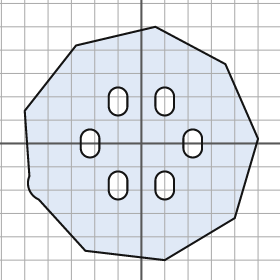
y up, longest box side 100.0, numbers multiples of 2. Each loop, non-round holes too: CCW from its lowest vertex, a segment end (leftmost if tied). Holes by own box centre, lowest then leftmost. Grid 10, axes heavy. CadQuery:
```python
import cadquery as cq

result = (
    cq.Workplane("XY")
    .moveTo(10.0, -50.0)
    .lineTo(40.0, -32.0)
    .lineTo(50.0, 2.0)
    .lineTo(36.0, 34.0)
    .lineTo(6.0, 50.0)
    .lineTo(-28.0, 42.0)
    .lineTo(-50.0, 14.0)
    .lineTo(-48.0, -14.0)
    .threePointArc((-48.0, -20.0), (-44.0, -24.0))
    .lineTo(-24.0, -46.0)
    .close()
    .moveTo(-14.0, -20.0)
    .threePointArc((-10.0, -24.0), (-6.0, -20.0))
    .lineTo(-6.0, -16.0)
    .threePointArc((-10.0, -12.0), (-14.0, -16.0))
    .close()
    .moveTo(6.0, -20.0)
    .threePointArc((10.0, -24.0), (14.0, -20.0))
    .lineTo(14.0, -16.0)
    .threePointArc((10.0, -12.0), (6.0, -16.0))
    .close()
    .moveTo(-26.0, -2.0)
    .threePointArc((-22.0, -6.0), (-18.0, -2.0))
    .lineTo(-18.0, 2.0)
    .threePointArc((-22.0, 6.0), (-26.0, 2.0))
    .close()
    .moveTo(18.0, -2.0)
    .threePointArc((22.0, -6.0), (26.0, -2.0))
    .lineTo(26.0, 2.0)
    .threePointArc((22.0, 6.0), (18.0, 2.0))
    .close()
    .moveTo(-14.0, 16.0)
    .threePointArc((-10.0, 12.0), (-6.0, 16.0))
    .lineTo(-6.0, 20.0)
    .threePointArc((-10.0, 24.0), (-14.0, 20.0))
    .close()
    .moveTo(6.0, 16.0)
    .threePointArc((10.0, 12.0), (14.0, 16.0))
    .lineTo(14.0, 20.0)
    .threePointArc((10.0, 24.0), (6.0, 20.0))
    .close()
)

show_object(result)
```